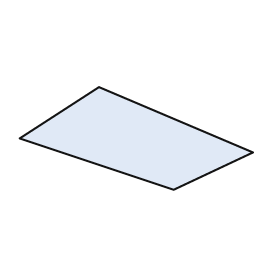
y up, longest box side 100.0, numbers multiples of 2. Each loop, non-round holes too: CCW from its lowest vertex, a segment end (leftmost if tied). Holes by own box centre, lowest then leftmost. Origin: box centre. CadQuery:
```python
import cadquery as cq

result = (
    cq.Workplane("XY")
    .moveTo(16.0, -22.0)
    .lineTo(50.0, -6.0)
    .lineTo(-16.0, 22.0)
    .lineTo(-50.0, 0.0)
    .close()
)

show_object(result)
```